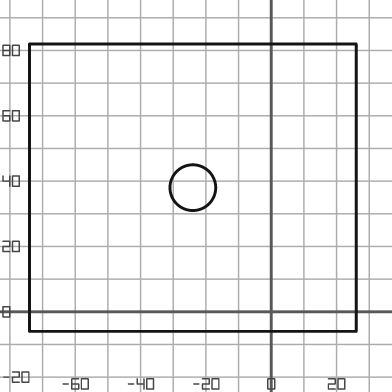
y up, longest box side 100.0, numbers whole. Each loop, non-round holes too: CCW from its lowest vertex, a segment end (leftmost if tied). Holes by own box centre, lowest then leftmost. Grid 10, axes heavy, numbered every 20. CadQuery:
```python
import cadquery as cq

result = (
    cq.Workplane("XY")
    .moveTo(-74.0, -6.0)
    .lineTo(26.0, -6.0)
    .lineTo(26.0, 82.0)
    .lineTo(-74.0, 82.0)
    .close()
    .moveTo(-24.0, 38.0)
    .circle(7.0)
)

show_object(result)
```